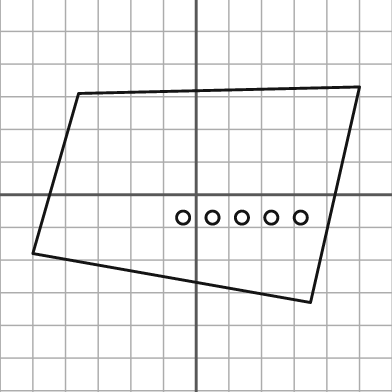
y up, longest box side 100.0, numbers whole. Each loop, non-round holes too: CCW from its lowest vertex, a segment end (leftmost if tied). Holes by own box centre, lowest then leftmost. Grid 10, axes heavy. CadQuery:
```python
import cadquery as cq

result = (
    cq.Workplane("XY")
    .moveTo(35.0, -33.0)
    .lineTo(50.0, 33.0)
    .lineTo(-36.0, 31.0)
    .lineTo(-50.0, -18.0)
    .close()
    .moveTo(-4.0, -7.0)
    .circle(2.0)
    .moveTo(5.0, -7.0)
    .circle(2.0)
    .moveTo(14.0, -7.0)
    .circle(2.0)
    .moveTo(23.0, -7.0)
    .circle(2.0)
    .moveTo(32.0, -7.0)
    .circle(2.0)
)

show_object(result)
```